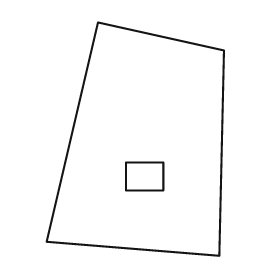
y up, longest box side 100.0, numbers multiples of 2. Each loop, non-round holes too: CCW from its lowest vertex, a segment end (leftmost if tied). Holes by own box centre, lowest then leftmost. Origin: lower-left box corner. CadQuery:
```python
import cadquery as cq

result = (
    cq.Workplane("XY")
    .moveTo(74.0, 0.0)
    .lineTo(76.0, 88.0)
    .lineTo(22.0, 100.0)
    .lineTo(0.0, 6.0)
    .close()
    .moveTo(34.0, 28.0)
    .lineTo(50.0, 28.0)
    .lineTo(50.0, 40.0)
    .lineTo(34.0, 40.0)
    .close()
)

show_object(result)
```